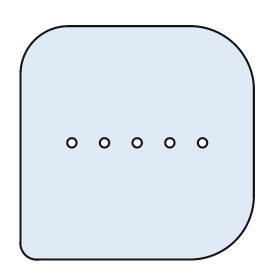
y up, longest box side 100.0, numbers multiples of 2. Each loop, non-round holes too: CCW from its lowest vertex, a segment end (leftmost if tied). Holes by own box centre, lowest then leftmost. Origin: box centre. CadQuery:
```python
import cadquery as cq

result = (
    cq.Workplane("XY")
    .moveTo(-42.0, -50.0)
    .lineTo(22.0, -50.0)
    .threePointArc((42.0, -42.0), (50.0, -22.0))
    .lineTo(50.0, 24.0)
    .threePointArc((42.0, 42.0), (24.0, 50.0))
    .lineTo(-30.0, 50.0)
    .threePointArc((-44.0, 44.0), (-50.0, 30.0))
    .lineTo(-50.0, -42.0)
    .threePointArc((-48.0, -48.0), (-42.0, -50.0))
    .close()
    .moveTo(-28.0, 0.0)
    .circle(2.0)
    .moveTo(-14.0, 0.0)
    .circle(2.0)
    .moveTo(0.0, 0.0)
    .circle(2.0)
    .moveTo(14.0, 0.0)
    .circle(2.0)
    .moveTo(28.0, 0.0)
    .circle(2.0)
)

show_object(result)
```